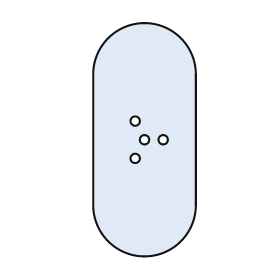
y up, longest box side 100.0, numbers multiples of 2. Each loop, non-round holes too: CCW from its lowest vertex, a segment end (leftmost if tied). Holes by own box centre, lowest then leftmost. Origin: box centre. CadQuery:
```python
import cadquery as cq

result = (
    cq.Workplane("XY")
    .moveTo(-22.0, -28.0)
    .threePointArc((0.0, -50.0), (22.0, -28.0))
    .lineTo(22.0, 28.0)
    .threePointArc((0.0, 50.0), (-22.0, 28.0))
    .close()
    .moveTo(-4.0, -8.0)
    .circle(2.0)
    .moveTo(0.0, 0.0)
    .circle(2.0)
    .moveTo(8.0, 0.0)
    .circle(2.0)
    .moveTo(-4.0, 8.0)
    .circle(2.0)
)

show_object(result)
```